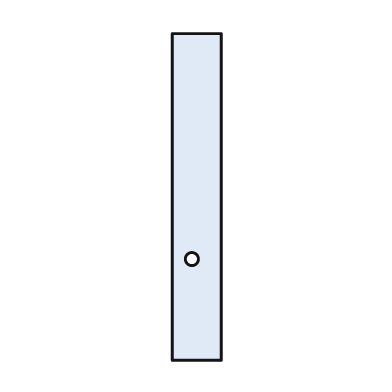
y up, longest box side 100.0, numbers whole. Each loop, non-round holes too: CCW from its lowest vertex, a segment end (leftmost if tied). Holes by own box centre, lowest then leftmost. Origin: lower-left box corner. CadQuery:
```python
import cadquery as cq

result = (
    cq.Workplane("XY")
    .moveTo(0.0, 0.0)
    .lineTo(15.0, 0.0)
    .lineTo(15.0, 100.0)
    .lineTo(0.0, 100.0)
    .close()
    .moveTo(6.0, 31.0)
    .circle(2.0)
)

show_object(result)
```